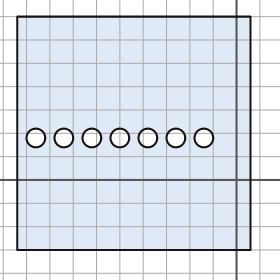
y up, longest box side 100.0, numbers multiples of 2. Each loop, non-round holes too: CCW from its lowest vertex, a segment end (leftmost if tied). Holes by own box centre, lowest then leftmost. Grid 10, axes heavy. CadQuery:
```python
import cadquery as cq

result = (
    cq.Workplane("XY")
    .moveTo(-94.0, -30.0)
    .lineTo(6.0, -30.0)
    .lineTo(6.0, 70.0)
    .lineTo(-94.0, 70.0)
    .close()
    .moveTo(-86.0, 18.0)
    .circle(4.0)
    .moveTo(-74.0, 18.0)
    .circle(4.0)
    .moveTo(-62.0, 18.0)
    .circle(4.0)
    .moveTo(-50.0, 18.0)
    .circle(4.0)
    .moveTo(-38.0, 18.0)
    .circle(4.0)
    .moveTo(-26.0, 18.0)
    .circle(4.0)
    .moveTo(-14.0, 18.0)
    .circle(4.0)
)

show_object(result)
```